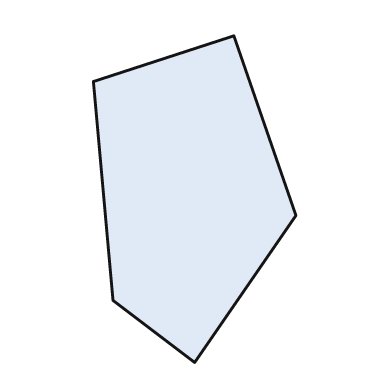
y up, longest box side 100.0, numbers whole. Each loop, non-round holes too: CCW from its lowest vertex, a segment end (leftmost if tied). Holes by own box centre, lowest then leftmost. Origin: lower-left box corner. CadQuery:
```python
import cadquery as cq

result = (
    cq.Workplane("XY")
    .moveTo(31.0, 0.0)
    .lineTo(62.0, 45.0)
    .lineTo(43.0, 100.0)
    .lineTo(0.0, 86.0)
    .lineTo(6.0, 19.0)
    .close()
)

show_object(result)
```